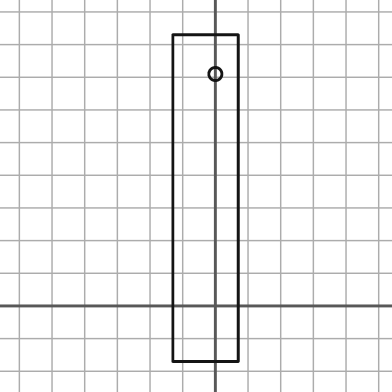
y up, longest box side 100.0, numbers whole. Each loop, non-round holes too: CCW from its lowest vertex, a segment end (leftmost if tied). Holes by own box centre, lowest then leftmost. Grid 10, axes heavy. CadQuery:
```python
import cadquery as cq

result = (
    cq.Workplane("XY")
    .moveTo(-13.0, -17.0)
    .lineTo(7.0, -17.0)
    .lineTo(7.0, 83.0)
    .lineTo(-13.0, 83.0)
    .close()
    .moveTo(0.0, 71.0)
    .circle(2.0)
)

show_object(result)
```